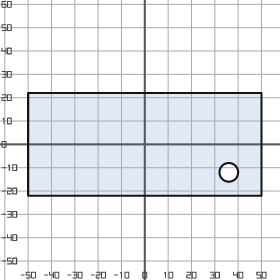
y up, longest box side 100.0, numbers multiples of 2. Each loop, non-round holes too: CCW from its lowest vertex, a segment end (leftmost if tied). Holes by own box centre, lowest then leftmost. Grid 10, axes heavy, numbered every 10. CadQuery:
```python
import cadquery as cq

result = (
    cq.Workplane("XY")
    .moveTo(-50.0, -22.0)
    .lineTo(50.0, -22.0)
    .lineTo(50.0, 22.0)
    .lineTo(-50.0, 22.0)
    .close()
    .moveTo(36.0, -12.0)
    .circle(4.0)
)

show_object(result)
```